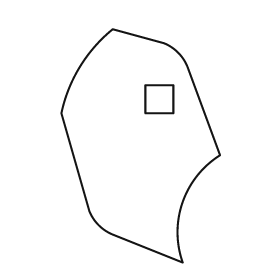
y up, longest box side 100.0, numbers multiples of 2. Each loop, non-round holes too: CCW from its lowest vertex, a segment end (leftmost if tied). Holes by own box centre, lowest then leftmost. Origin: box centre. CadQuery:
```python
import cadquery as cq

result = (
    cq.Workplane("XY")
    .moveTo(18.0, -50.0)
    .threePointArc((18.0, -24.0), (34.0, -4.0))
    .lineTo(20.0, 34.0)
    .threePointArc((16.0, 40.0), (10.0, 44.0))
    .lineTo(-12.0, 50.0)
    .threePointArc((-26.0, 34.0), (-34.0, 14.0))
    .lineTo(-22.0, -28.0)
    .threePointArc((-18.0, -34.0), (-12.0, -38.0))
    .close()
    .moveTo(2.0, 14.0)
    .lineTo(14.0, 14.0)
    .lineTo(14.0, 26.0)
    .lineTo(2.0, 26.0)
    .close()
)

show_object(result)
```